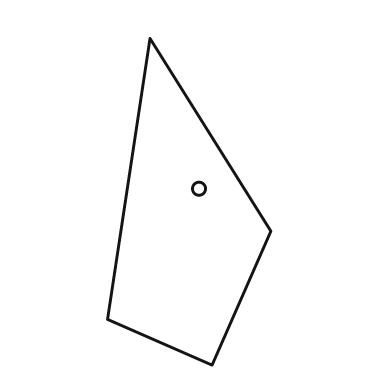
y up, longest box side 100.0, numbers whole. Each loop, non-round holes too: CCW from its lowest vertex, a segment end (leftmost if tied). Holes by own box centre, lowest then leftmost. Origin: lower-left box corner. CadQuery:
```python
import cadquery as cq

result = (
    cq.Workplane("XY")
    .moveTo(32.0, 0.0)
    .lineTo(50.0, 41.0)
    .lineTo(13.0, 100.0)
    .lineTo(0.0, 14.0)
    .close()
    .moveTo(28.0, 54.0)
    .circle(2.0)
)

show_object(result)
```